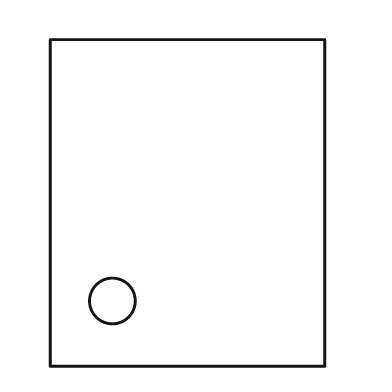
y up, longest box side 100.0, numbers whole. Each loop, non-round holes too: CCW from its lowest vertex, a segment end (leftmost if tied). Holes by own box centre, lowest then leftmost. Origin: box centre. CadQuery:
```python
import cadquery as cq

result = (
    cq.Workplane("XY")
    .moveTo(-42.0, -50.0)
    .lineTo(42.0, -50.0)
    .lineTo(42.0, 50.0)
    .lineTo(-42.0, 50.0)
    .close()
    .moveTo(-23.0, -30.0)
    .circle(7.0)
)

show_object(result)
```